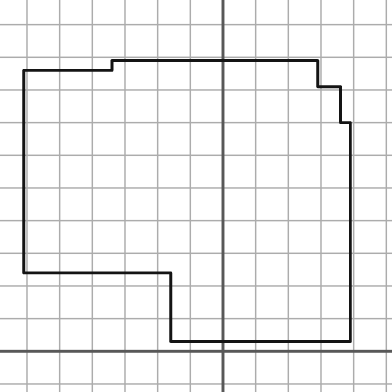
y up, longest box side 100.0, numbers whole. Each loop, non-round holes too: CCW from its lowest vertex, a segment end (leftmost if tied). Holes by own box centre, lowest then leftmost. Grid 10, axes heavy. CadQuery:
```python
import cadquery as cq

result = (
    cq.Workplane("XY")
    .moveTo(-16.0, 3.0)
    .lineTo(39.0, 3.0)
    .lineTo(39.0, 70.0)
    .lineTo(36.0, 70.0)
    .lineTo(36.0, 81.0)
    .lineTo(29.0, 81.0)
    .lineTo(29.0, 89.0)
    .lineTo(-34.0, 89.0)
    .lineTo(-34.0, 86.0)
    .lineTo(-61.0, 86.0)
    .lineTo(-61.0, 24.0)
    .lineTo(-16.0, 24.0)
    .close()
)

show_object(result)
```